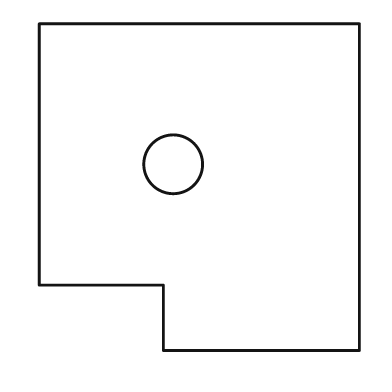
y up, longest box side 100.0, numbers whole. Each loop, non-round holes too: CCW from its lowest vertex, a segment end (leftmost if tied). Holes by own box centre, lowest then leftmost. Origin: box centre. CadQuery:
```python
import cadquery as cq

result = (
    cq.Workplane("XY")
    .moveTo(-11.0, -50.0)
    .lineTo(49.0, -50.0)
    .lineTo(49.0, 50.0)
    .lineTo(-49.0, 50.0)
    .lineTo(-49.0, -30.0)
    .lineTo(-11.0, -30.0)
    .close()
    .moveTo(-8.0, 7.0)
    .circle(9.0)
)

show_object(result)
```